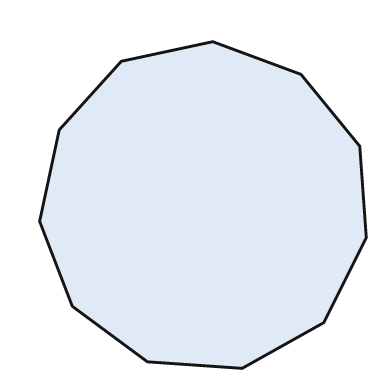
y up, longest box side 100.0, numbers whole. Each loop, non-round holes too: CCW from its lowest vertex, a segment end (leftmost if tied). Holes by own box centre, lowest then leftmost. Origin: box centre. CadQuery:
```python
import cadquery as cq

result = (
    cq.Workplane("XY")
    .moveTo(12.0, -50.0)
    .lineTo(37.0, -36.0)
    .lineTo(50.0, -10.0)
    .lineTo(48.0, 18.0)
    .lineTo(30.0, 40.0)
    .lineTo(3.0, 50.0)
    .lineTo(-25.0, 44.0)
    .lineTo(-44.0, 23.0)
    .lineTo(-50.0, -5.0)
    .lineTo(-40.0, -31.0)
    .lineTo(-17.0, -48.0)
    .close()
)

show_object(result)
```